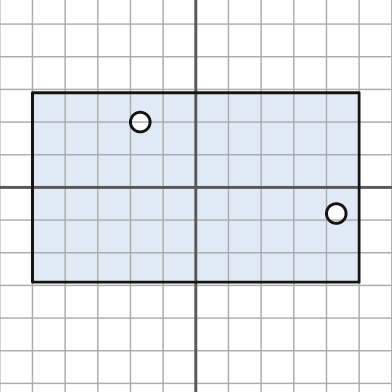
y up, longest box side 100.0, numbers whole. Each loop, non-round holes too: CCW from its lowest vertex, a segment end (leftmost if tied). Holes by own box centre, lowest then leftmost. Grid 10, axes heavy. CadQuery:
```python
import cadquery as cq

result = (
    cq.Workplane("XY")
    .moveTo(-50.0, -29.0)
    .lineTo(50.0, -29.0)
    .lineTo(50.0, 29.0)
    .lineTo(-50.0, 29.0)
    .close()
    .moveTo(43.0, -8.0)
    .circle(3.0)
    .moveTo(-17.0, 20.0)
    .circle(3.0)
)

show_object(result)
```